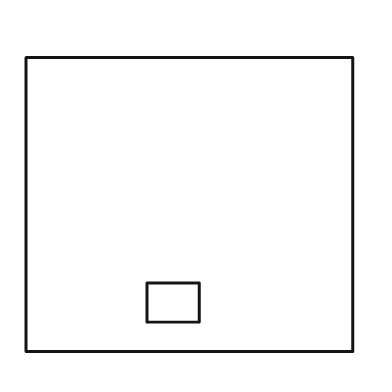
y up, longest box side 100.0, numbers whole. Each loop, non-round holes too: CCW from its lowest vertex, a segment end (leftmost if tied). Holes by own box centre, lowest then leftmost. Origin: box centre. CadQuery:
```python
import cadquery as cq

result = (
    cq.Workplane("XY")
    .moveTo(-50.0, -45.0)
    .lineTo(50.0, -45.0)
    .lineTo(50.0, 45.0)
    .lineTo(-50.0, 45.0)
    .close()
    .moveTo(-13.0, -36.0)
    .lineTo(3.0, -36.0)
    .lineTo(3.0, -24.0)
    .lineTo(-13.0, -24.0)
    .close()
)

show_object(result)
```